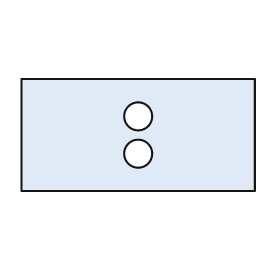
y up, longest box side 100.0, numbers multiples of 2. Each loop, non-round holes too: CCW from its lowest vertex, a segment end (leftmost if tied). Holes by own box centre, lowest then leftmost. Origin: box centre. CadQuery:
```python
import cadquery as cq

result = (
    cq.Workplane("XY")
    .moveTo(-50.0, -24.0)
    .lineTo(50.0, -24.0)
    .lineTo(50.0, 24.0)
    .lineTo(-50.0, 24.0)
    .close()
    .moveTo(0.0, -8.0)
    .circle(6.0)
    .moveTo(0.0, 8.0)
    .circle(6.0)
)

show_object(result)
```